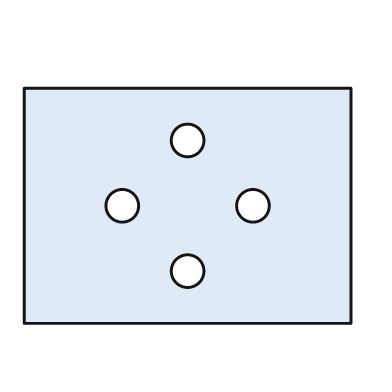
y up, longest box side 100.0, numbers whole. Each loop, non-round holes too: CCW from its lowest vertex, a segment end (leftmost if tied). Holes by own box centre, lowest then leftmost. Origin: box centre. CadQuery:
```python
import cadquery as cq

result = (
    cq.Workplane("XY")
    .moveTo(-50.0, -36.0)
    .lineTo(50.0, -36.0)
    .lineTo(50.0, 36.0)
    .lineTo(-50.0, 36.0)
    .close()
    .moveTo(0.0, -20.0)
    .circle(5.0)
    .moveTo(-20.0, 0.0)
    .circle(5.0)
    .moveTo(20.0, 0.0)
    .circle(5.0)
    .moveTo(0.0, 20.0)
    .circle(5.0)
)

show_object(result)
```